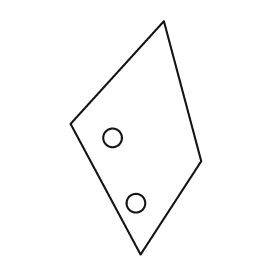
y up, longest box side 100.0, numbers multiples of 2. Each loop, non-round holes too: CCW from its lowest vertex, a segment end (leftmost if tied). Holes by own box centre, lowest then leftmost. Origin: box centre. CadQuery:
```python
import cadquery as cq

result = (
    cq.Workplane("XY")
    .moveTo(2.0, -50.0)
    .lineTo(28.0, -10.0)
    .lineTo(12.0, 50.0)
    .lineTo(-28.0, 6.0)
    .close()
    .moveTo(0.0, -28.0)
    .circle(4.0)
    .moveTo(-10.0, 0.0)
    .circle(4.0)
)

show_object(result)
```